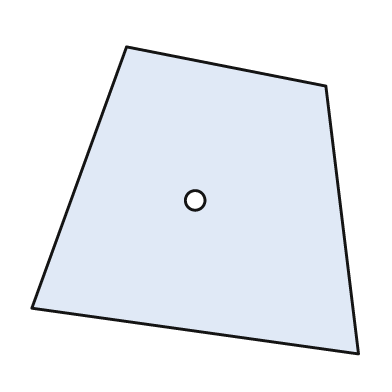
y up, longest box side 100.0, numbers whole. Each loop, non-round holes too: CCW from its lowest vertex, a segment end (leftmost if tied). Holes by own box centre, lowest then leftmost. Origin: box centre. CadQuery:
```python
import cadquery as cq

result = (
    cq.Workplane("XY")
    .moveTo(50.0, -47.0)
    .lineTo(40.0, 35.0)
    .lineTo(-21.0, 47.0)
    .lineTo(-50.0, -33.0)
    .close()
    .moveTo(0.0, 0.0)
    .circle(3.0)
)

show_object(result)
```